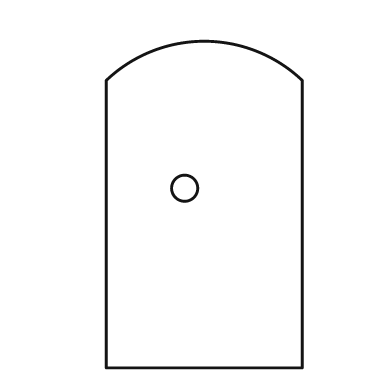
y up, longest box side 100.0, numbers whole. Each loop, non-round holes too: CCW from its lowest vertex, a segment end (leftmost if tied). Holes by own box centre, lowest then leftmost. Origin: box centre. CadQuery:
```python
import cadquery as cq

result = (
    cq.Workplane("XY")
    .moveTo(-30.0, -50.0)
    .lineTo(30.0, -50.0)
    .lineTo(30.0, 38.0)
    .threePointArc((0.0, 50.0), (-30.0, 38.0))
    .close()
    .moveTo(-6.0, 5.0)
    .circle(4.0)
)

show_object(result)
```